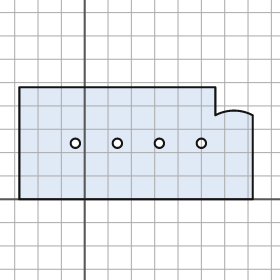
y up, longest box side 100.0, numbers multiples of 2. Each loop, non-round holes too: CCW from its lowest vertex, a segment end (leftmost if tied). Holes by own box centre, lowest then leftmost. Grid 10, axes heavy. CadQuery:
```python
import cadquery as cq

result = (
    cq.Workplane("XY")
    .moveTo(-28.0, 0.0)
    .lineTo(72.0, 0.0)
    .lineTo(72.0, 36.0)
    .threePointArc((64.0, 38.0), (56.0, 36.0))
    .lineTo(56.0, 48.0)
    .lineTo(-28.0, 48.0)
    .close()
    .moveTo(-4.0, 24.0)
    .circle(2.0)
    .moveTo(14.0, 24.0)
    .circle(2.0)
    .moveTo(32.0, 24.0)
    .circle(2.0)
    .moveTo(50.0, 24.0)
    .circle(2.0)
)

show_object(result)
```